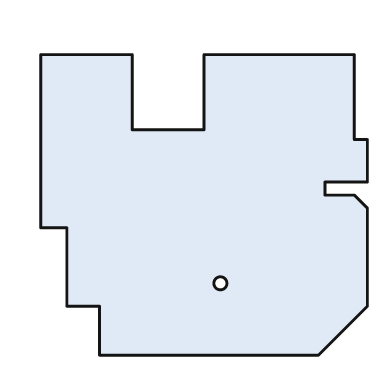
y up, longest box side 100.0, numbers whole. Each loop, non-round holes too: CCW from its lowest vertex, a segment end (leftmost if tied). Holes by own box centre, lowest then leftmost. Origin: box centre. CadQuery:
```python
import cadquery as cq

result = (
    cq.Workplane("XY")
    .moveTo(-32.0, -46.0)
    .lineTo(35.0, -46.0)
    .lineTo(50.0, -31.0)
    .lineTo(50.0, -1.0)
    .lineTo(46.0, 3.0)
    .lineTo(37.0, 3.0)
    .lineTo(37.0, 7.0)
    .lineTo(50.0, 7.0)
    .lineTo(50.0, 20.0)
    .lineTo(46.0, 20.0)
    .lineTo(46.0, 46.0)
    .lineTo(0.0, 46.0)
    .lineTo(0.0, 23.0)
    .lineTo(-22.0, 23.0)
    .lineTo(-22.0, 46.0)
    .lineTo(-50.0, 46.0)
    .lineTo(-50.0, -7.0)
    .lineTo(-42.0, -7.0)
    .lineTo(-42.0, -31.0)
    .lineTo(-32.0, -31.0)
    .close()
    .moveTo(5.0, -24.0)
    .circle(2.0)
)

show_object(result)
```